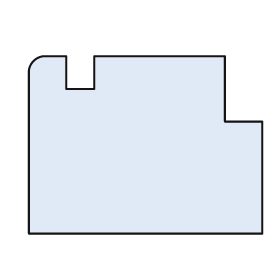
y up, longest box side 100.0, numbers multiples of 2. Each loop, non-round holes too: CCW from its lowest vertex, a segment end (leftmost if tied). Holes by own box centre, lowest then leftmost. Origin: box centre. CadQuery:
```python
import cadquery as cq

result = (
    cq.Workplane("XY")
    .moveTo(-50.0, -38.0)
    .lineTo(50.0, -38.0)
    .lineTo(50.0, 10.0)
    .lineTo(34.0, 10.0)
    .lineTo(34.0, 38.0)
    .lineTo(-22.0, 38.0)
    .lineTo(-22.0, 24.0)
    .lineTo(-34.0, 24.0)
    .lineTo(-34.0, 38.0)
    .lineTo(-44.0, 38.0)
    .threePointArc((-48.0, 36.0), (-50.0, 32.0))
    .close()
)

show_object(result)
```